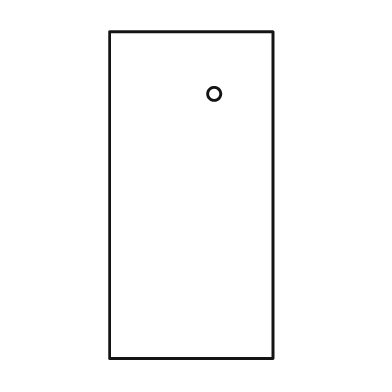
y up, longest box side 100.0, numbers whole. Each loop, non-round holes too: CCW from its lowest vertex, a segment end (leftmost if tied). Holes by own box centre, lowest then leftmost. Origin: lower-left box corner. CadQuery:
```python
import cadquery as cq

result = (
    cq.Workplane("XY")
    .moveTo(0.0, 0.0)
    .lineTo(50.0, 0.0)
    .lineTo(50.0, 100.0)
    .lineTo(0.0, 100.0)
    .close()
    .moveTo(32.0, 81.0)
    .circle(2.0)
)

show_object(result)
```